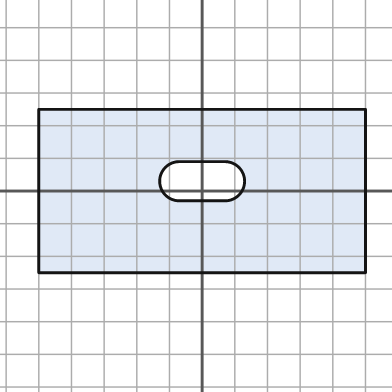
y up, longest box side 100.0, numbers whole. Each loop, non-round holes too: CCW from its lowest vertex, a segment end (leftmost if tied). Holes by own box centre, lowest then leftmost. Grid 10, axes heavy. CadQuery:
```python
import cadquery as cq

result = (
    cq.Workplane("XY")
    .moveTo(-50.0, -25.0)
    .lineTo(50.0, -25.0)
    .lineTo(50.0, 25.0)
    .lineTo(-50.0, 25.0)
    .close()
    .moveTo(-7.0, -3.0)
    .lineTo(7.0, -3.0)
    .threePointArc((13.0, 3.0), (7.0, 9.0))
    .lineTo(-7.0, 9.0)
    .threePointArc((-13.0, 3.0), (-7.0, -3.0))
    .close()
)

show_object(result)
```